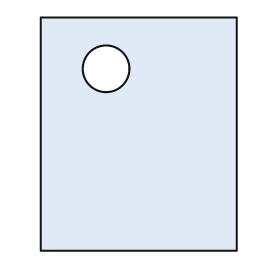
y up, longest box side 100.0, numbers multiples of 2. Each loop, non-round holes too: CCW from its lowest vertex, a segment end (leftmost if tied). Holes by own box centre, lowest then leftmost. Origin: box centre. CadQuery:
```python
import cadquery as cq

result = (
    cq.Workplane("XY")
    .moveTo(-42.0, -50.0)
    .lineTo(42.0, -50.0)
    .lineTo(42.0, 50.0)
    .lineTo(-42.0, 50.0)
    .close()
    .moveTo(-14.0, 28.0)
    .circle(10.0)
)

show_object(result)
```